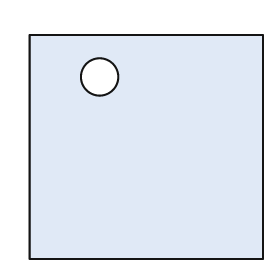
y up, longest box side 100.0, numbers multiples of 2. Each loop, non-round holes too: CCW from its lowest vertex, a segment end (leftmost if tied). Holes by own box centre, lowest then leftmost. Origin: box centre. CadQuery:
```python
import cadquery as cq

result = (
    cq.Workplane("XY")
    .moveTo(-50.0, -48.0)
    .lineTo(50.0, -48.0)
    .lineTo(50.0, 48.0)
    .lineTo(-50.0, 48.0)
    .close()
    .moveTo(-20.0, 30.0)
    .circle(8.0)
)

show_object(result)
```